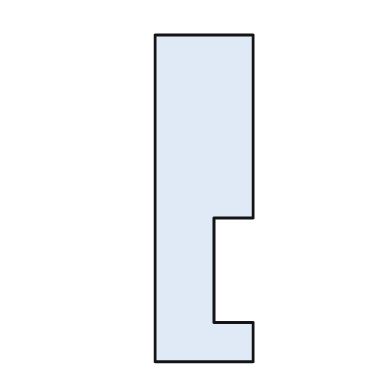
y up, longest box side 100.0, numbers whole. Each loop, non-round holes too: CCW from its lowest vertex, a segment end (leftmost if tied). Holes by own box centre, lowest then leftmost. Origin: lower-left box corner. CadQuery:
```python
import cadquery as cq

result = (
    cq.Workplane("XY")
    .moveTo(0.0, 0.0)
    .lineTo(30.0, 0.0)
    .lineTo(30.0, 12.0)
    .lineTo(18.0, 12.0)
    .lineTo(18.0, 44.0)
    .lineTo(30.0, 44.0)
    .lineTo(30.0, 100.0)
    .lineTo(0.0, 100.0)
    .close()
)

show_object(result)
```